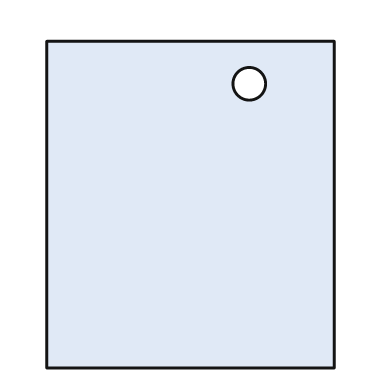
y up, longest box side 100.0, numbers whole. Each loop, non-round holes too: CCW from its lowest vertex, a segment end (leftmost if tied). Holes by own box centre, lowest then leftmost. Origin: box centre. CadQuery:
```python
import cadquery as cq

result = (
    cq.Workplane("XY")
    .moveTo(-44.0, -50.0)
    .lineTo(44.0, -50.0)
    .lineTo(44.0, 50.0)
    .lineTo(-44.0, 50.0)
    .close()
    .moveTo(18.0, 37.0)
    .circle(5.0)
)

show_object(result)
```